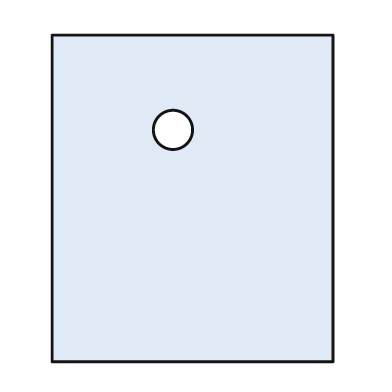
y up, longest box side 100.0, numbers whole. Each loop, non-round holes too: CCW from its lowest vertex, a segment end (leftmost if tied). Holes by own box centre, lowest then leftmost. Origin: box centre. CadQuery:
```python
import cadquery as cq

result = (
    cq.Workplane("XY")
    .moveTo(-43.0, -50.0)
    .lineTo(43.0, -50.0)
    .lineTo(43.0, 50.0)
    .lineTo(-43.0, 50.0)
    .close()
    .moveTo(-6.0, 21.0)
    .circle(6.0)
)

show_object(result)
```